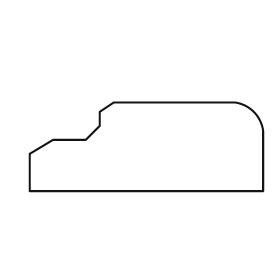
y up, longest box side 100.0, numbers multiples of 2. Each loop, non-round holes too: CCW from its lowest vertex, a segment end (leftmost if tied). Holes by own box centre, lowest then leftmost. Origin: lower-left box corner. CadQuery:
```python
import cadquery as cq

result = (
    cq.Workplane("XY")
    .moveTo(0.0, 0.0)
    .lineTo(100.0, 0.0)
    .lineTo(100.0, 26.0)
    .threePointArc((96.0, 34.0), (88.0, 38.0))
    .lineTo(36.0, 38.0)
    .lineTo(30.0, 34.0)
    .lineTo(30.0, 28.0)
    .lineTo(24.0, 22.0)
    .lineTo(10.0, 22.0)
    .lineTo(0.0, 16.0)
    .close()
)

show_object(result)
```